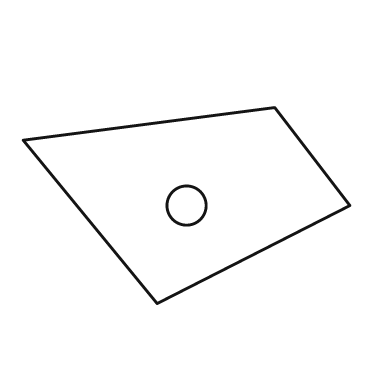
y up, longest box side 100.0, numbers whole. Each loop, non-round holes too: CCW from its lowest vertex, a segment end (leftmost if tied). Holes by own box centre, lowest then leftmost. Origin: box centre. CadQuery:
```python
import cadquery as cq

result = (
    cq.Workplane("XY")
    .moveTo(-9.0, -30.0)
    .lineTo(50.0, 0.0)
    .lineTo(27.0, 30.0)
    .lineTo(-50.0, 20.0)
    .close()
    .moveTo(0.0, 0.0)
    .circle(6.0)
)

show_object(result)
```